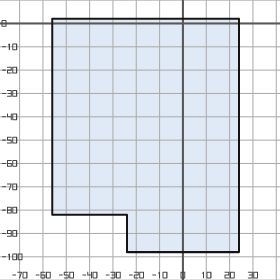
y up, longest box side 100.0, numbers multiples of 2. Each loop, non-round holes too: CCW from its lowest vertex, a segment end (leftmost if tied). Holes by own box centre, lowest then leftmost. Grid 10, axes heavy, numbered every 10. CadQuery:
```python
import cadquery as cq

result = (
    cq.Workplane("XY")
    .moveTo(-24.0, -98.0)
    .lineTo(24.0, -98.0)
    .lineTo(24.0, 2.0)
    .lineTo(-56.0, 2.0)
    .lineTo(-56.0, -82.0)
    .lineTo(-24.0, -82.0)
    .close()
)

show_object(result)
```